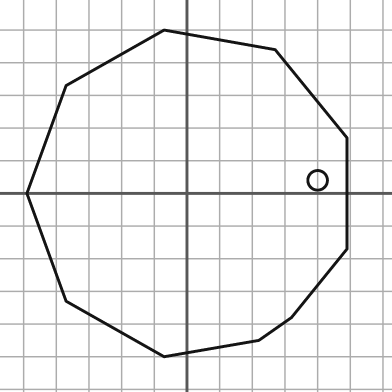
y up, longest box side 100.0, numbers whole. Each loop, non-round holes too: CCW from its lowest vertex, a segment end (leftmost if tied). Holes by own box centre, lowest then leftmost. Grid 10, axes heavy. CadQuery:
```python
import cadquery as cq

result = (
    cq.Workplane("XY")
    .moveTo(-7.0, -50.0)
    .lineTo(22.0, -45.0)
    .lineTo(32.0, -38.0)
    .lineTo(49.0, -17.0)
    .lineTo(49.0, 17.0)
    .lineTo(27.0, 44.0)
    .lineTo(-7.0, 50.0)
    .lineTo(-37.0, 33.0)
    .lineTo(-49.0, 0.0)
    .lineTo(-37.0, -33.0)
    .close()
    .moveTo(40.0, 4.0)
    .circle(3.0)
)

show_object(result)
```